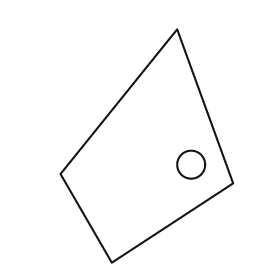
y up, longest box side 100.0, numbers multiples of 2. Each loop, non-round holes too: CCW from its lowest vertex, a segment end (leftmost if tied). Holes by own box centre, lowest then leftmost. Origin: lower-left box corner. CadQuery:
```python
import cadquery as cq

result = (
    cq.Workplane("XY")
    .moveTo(22.0, 0.0)
    .lineTo(74.0, 34.0)
    .lineTo(50.0, 100.0)
    .lineTo(0.0, 38.0)
    .close()
    .moveTo(56.0, 42.0)
    .circle(6.0)
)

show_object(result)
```